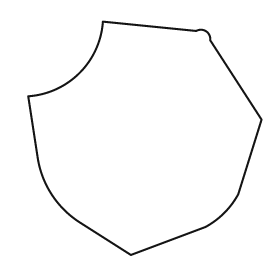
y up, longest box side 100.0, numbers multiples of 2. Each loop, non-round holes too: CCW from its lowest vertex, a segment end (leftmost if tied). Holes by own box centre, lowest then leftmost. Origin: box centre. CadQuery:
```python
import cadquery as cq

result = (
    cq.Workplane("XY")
    .moveTo(-6.0, -50.0)
    .lineTo(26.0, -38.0)
    .threePointArc((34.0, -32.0), (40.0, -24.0))
    .lineTo(50.0, 8.0)
    .lineTo(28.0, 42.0)
    .threePointArc((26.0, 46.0), (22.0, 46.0))
    .lineTo(-18.0, 50.0)
    .threePointArc((-28.0, 28.0), (-50.0, 18.0))
    .lineTo(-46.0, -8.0)
    .threePointArc((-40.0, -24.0), (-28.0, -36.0))
    .close()
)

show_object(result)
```